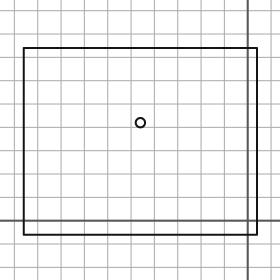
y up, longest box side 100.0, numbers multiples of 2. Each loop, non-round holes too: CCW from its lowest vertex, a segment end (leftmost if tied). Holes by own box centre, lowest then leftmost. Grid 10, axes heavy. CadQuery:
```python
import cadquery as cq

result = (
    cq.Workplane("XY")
    .moveTo(-96.0, -6.0)
    .lineTo(4.0, -6.0)
    .lineTo(4.0, 74.0)
    .lineTo(-96.0, 74.0)
    .close()
    .moveTo(-46.0, 42.0)
    .circle(2.0)
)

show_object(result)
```